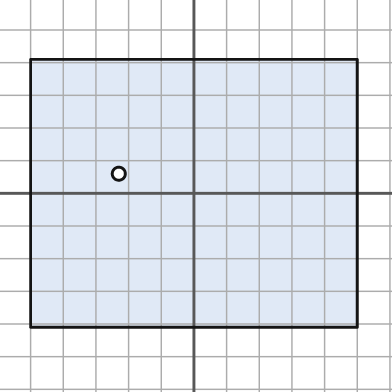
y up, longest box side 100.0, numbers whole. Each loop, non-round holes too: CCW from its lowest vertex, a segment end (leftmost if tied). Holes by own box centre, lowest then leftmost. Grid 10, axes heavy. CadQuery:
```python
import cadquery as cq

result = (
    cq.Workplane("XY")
    .moveTo(-50.0, -41.0)
    .lineTo(50.0, -41.0)
    .lineTo(50.0, 41.0)
    .lineTo(-50.0, 41.0)
    .close()
    .moveTo(-23.0, 6.0)
    .circle(2.0)
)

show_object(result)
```